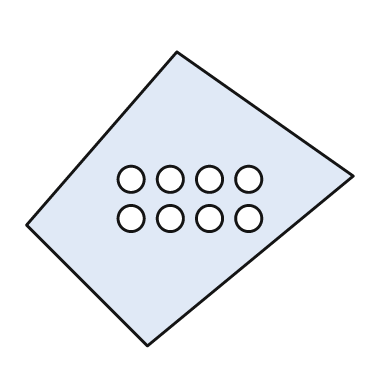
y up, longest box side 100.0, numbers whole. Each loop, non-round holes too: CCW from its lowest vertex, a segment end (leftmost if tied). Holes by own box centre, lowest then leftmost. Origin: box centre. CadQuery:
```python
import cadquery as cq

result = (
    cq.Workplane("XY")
    .moveTo(-13.0, -45.0)
    .lineTo(50.0, 7.0)
    .lineTo(-4.0, 45.0)
    .lineTo(-50.0, -8.0)
    .close()
    .moveTo(-18.0, -6.0)
    .circle(4.0)
    .moveTo(-6.0, -6.0)
    .circle(4.0)
    .moveTo(6.0, -6.0)
    .circle(4.0)
    .moveTo(18.0, -6.0)
    .circle(4.0)
    .moveTo(-18.0, 6.0)
    .circle(4.0)
    .moveTo(-6.0, 6.0)
    .circle(4.0)
    .moveTo(6.0, 6.0)
    .circle(4.0)
    .moveTo(18.0, 6.0)
    .circle(4.0)
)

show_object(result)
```